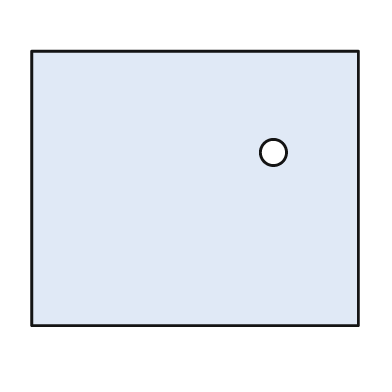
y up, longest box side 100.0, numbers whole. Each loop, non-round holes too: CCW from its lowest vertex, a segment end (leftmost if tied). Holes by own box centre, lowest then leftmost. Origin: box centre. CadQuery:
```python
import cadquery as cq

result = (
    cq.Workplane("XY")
    .moveTo(-50.0, -42.0)
    .lineTo(50.0, -42.0)
    .lineTo(50.0, 42.0)
    .lineTo(-50.0, 42.0)
    .close()
    .moveTo(24.0, 11.0)
    .circle(4.0)
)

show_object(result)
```